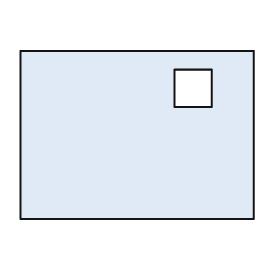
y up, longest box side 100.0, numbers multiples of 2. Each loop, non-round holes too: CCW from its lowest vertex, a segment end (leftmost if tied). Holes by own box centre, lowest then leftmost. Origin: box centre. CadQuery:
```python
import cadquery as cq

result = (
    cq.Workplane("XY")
    .moveTo(-50.0, -36.0)
    .lineTo(50.0, -36.0)
    .lineTo(50.0, 36.0)
    .lineTo(-50.0, 36.0)
    .close()
    .moveTo(16.0, 12.0)
    .lineTo(32.0, 12.0)
    .lineTo(32.0, 28.0)
    .lineTo(16.0, 28.0)
    .close()
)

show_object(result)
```